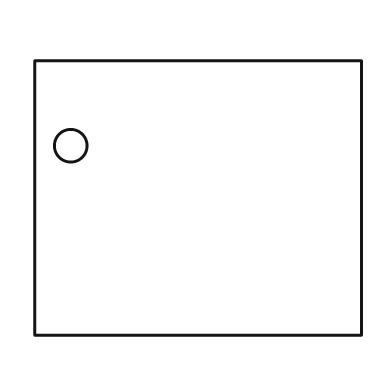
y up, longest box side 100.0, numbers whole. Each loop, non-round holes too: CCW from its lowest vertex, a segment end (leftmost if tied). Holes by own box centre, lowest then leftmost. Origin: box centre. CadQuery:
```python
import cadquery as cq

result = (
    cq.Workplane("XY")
    .moveTo(-50.0, -42.0)
    .lineTo(50.0, -42.0)
    .lineTo(50.0, 42.0)
    .lineTo(-50.0, 42.0)
    .close()
    .moveTo(-39.0, 16.0)
    .circle(5.0)
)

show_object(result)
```